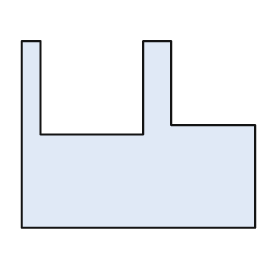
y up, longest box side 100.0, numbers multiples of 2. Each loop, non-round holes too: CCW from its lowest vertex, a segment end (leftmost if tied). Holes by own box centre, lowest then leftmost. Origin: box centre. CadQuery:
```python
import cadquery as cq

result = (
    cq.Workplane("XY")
    .moveTo(-50.0, -40.0)
    .lineTo(50.0, -40.0)
    .lineTo(50.0, 4.0)
    .lineTo(14.0, 4.0)
    .lineTo(14.0, 40.0)
    .lineTo(2.0, 40.0)
    .lineTo(2.0, 0.0)
    .lineTo(-42.0, 0.0)
    .lineTo(-42.0, 40.0)
    .lineTo(-50.0, 40.0)
    .close()
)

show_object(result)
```